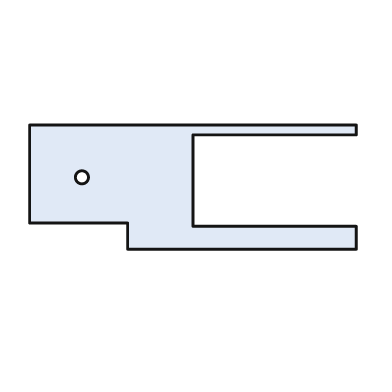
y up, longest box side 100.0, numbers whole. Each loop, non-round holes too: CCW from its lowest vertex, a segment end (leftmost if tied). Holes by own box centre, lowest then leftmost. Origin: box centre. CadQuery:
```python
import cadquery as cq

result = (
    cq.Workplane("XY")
    .moveTo(-20.0, -19.0)
    .lineTo(50.0, -19.0)
    .lineTo(50.0, -12.0)
    .lineTo(0.0, -12.0)
    .lineTo(0.0, 16.0)
    .lineTo(50.0, 16.0)
    .lineTo(50.0, 19.0)
    .lineTo(-50.0, 19.0)
    .lineTo(-50.0, -11.0)
    .lineTo(-20.0, -11.0)
    .close()
    .moveTo(-34.0, 3.0)
    .circle(2.0)
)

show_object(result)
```